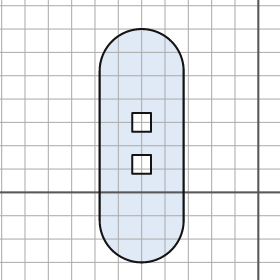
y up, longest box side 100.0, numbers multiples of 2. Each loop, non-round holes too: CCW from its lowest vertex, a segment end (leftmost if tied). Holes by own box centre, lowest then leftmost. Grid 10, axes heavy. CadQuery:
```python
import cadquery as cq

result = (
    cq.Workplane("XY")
    .moveTo(-68.0, -12.0)
    .threePointArc((-50.0, -30.0), (-32.0, -12.0))
    .lineTo(-32.0, 52.0)
    .threePointArc((-50.0, 70.0), (-68.0, 52.0))
    .close()
    .moveTo(-54.0, 8.0)
    .lineTo(-46.0, 8.0)
    .lineTo(-46.0, 16.0)
    .lineTo(-54.0, 16.0)
    .close()
    .moveTo(-54.0, 26.0)
    .lineTo(-46.0, 26.0)
    .lineTo(-46.0, 34.0)
    .lineTo(-54.0, 34.0)
    .close()
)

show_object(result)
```